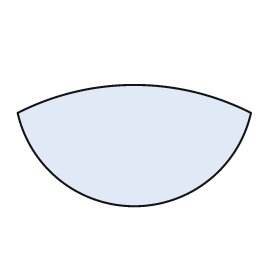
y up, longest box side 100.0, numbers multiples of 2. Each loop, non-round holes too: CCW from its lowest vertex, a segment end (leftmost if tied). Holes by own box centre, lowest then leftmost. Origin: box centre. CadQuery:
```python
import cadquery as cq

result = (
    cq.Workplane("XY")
    .moveTo(-50.0, 14.0)
    .threePointArc((0.0, -26.0), (50.0, 14.0))
    .threePointArc((0.0, 26.0), (-50.0, 14.0))
    .close()
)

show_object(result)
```